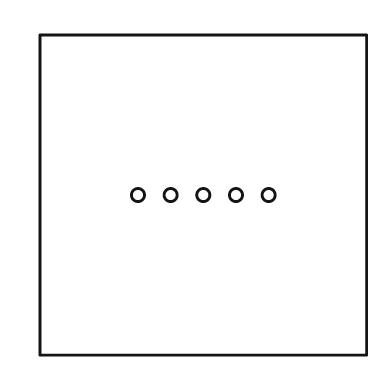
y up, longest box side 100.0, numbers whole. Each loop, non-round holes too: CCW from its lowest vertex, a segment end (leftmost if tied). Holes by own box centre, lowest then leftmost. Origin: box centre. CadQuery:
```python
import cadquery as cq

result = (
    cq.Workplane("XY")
    .moveTo(-50.0, -49.0)
    .lineTo(50.0, -49.0)
    .lineTo(50.0, 49.0)
    .lineTo(-50.0, 49.0)
    .close()
    .moveTo(-20.0, 0.0)
    .circle(2.0)
    .moveTo(-10.0, 0.0)
    .circle(2.0)
    .moveTo(0.0, 0.0)
    .circle(2.0)
    .moveTo(10.0, 0.0)
    .circle(2.0)
    .moveTo(20.0, 0.0)
    .circle(2.0)
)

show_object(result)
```